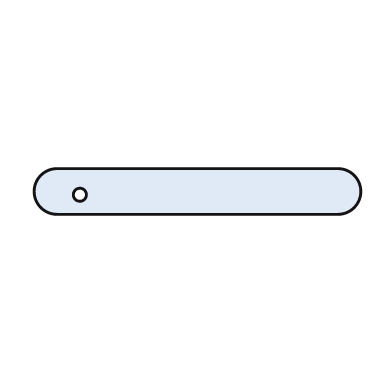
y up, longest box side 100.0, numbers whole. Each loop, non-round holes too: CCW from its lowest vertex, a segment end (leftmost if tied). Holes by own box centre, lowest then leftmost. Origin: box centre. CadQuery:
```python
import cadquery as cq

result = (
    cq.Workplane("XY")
    .moveTo(-43.0, -7.0)
    .lineTo(43.0, -7.0)
    .threePointArc((50.0, 0.0), (43.0, 7.0))
    .lineTo(-43.0, 7.0)
    .threePointArc((-50.0, 0.0), (-43.0, -7.0))
    .close()
    .moveTo(-36.0, -1.0)
    .circle(2.0)
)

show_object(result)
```